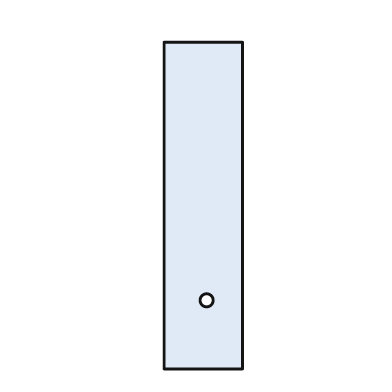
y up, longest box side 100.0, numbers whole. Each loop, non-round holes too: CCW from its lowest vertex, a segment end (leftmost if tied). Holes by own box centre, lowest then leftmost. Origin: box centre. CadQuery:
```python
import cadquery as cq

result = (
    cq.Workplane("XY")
    .moveTo(-12.0, -50.0)
    .lineTo(12.0, -50.0)
    .lineTo(12.0, 50.0)
    .lineTo(-12.0, 50.0)
    .close()
    .moveTo(1.0, -29.0)
    .circle(2.0)
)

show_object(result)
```